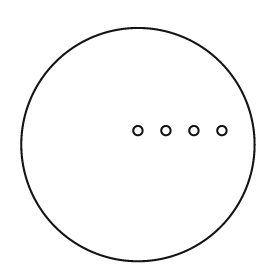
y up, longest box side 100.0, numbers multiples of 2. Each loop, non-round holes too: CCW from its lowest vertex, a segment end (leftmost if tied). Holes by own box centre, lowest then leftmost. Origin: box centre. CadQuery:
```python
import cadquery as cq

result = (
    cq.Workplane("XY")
    .moveTo(0.0, 0.0)
    .circle(50.0)
    .moveTo(0.0, 6.0)
    .circle(2.0)
    .moveTo(12.0, 6.0)
    .circle(2.0)
    .moveTo(24.0, 6.0)
    .circle(2.0)
    .moveTo(36.0, 6.0)
    .circle(2.0)
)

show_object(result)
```